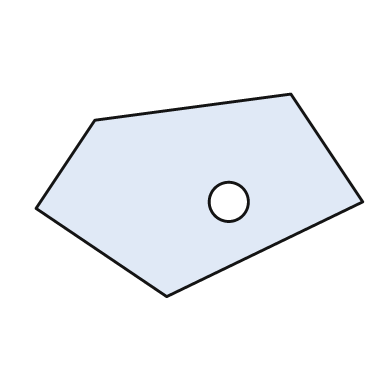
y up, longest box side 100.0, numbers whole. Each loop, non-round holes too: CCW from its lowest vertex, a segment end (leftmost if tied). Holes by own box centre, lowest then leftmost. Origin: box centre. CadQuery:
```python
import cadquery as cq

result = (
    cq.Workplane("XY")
    .moveTo(-10.0, -31.0)
    .lineTo(50.0, -2.0)
    .lineTo(28.0, 31.0)
    .lineTo(-32.0, 23.0)
    .lineTo(-50.0, -4.0)
    .close()
    .moveTo(9.0, -2.0)
    .circle(6.0)
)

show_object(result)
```